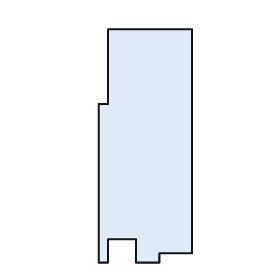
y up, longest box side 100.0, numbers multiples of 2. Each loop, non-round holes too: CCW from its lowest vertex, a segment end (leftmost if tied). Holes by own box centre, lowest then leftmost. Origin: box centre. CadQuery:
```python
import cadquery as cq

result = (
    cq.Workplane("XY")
    .moveTo(-20.0, -50.0)
    .lineTo(-16.0, -50.0)
    .lineTo(-16.0, -40.0)
    .lineTo(-4.0, -40.0)
    .lineTo(-4.0, -50.0)
    .lineTo(6.0, -50.0)
    .lineTo(6.0, -46.0)
    .lineTo(20.0, -46.0)
    .lineTo(20.0, 50.0)
    .lineTo(-16.0, 50.0)
    .lineTo(-16.0, 18.0)
    .lineTo(-20.0, 18.0)
    .close()
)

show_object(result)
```